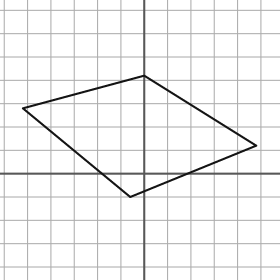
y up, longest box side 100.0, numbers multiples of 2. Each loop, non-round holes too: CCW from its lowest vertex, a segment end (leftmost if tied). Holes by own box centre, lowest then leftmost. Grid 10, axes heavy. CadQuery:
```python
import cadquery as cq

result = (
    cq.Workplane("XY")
    .moveTo(-6.0, -10.0)
    .lineTo(48.0, 12.0)
    .lineTo(0.0, 42.0)
    .lineTo(-52.0, 28.0)
    .close()
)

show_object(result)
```